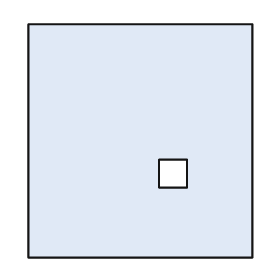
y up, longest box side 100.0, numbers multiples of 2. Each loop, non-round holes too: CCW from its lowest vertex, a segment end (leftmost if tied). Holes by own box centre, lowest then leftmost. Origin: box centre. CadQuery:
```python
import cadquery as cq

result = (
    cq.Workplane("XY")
    .moveTo(-48.0, -50.0)
    .lineTo(48.0, -50.0)
    .lineTo(48.0, 50.0)
    .lineTo(-48.0, 50.0)
    .close()
    .moveTo(8.0, -20.0)
    .lineTo(20.0, -20.0)
    .lineTo(20.0, -8.0)
    .lineTo(8.0, -8.0)
    .close()
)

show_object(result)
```